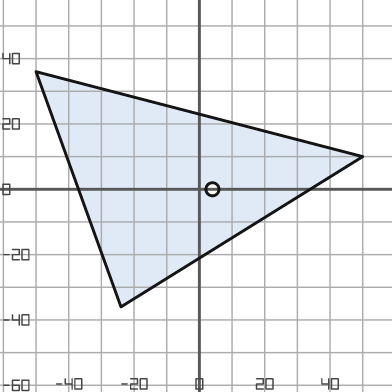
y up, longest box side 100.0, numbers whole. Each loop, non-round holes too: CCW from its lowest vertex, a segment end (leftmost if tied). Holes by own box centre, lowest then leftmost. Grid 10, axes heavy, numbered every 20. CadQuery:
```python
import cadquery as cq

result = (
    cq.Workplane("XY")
    .moveTo(-24.0, -36.0)
    .lineTo(50.0, 10.0)
    .lineTo(-50.0, 36.0)
    .close()
    .moveTo(4.0, 0.0)
    .circle(2.0)
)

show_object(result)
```